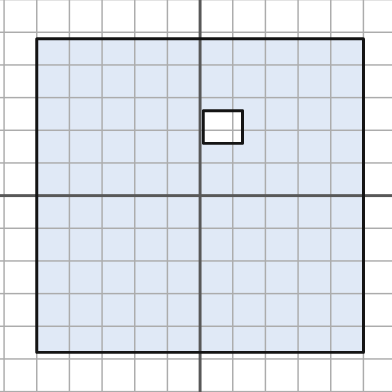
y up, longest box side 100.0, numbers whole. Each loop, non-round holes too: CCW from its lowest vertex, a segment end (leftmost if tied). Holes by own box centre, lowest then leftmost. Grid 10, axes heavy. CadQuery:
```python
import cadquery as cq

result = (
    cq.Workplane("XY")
    .moveTo(-50.0, -48.0)
    .lineTo(50.0, -48.0)
    .lineTo(50.0, 48.0)
    .lineTo(-50.0, 48.0)
    .close()
    .moveTo(1.0, 16.0)
    .lineTo(13.0, 16.0)
    .lineTo(13.0, 26.0)
    .lineTo(1.0, 26.0)
    .close()
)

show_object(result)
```